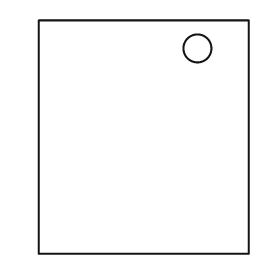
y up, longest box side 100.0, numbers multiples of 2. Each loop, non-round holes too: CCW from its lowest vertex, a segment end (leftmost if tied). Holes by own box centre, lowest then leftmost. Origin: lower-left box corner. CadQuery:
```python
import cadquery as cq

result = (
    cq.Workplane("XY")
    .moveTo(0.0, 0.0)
    .lineTo(90.0, 0.0)
    .lineTo(90.0, 100.0)
    .lineTo(0.0, 100.0)
    .close()
    .moveTo(68.0, 88.0)
    .circle(6.0)
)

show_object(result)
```